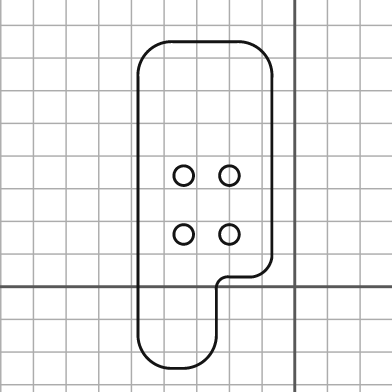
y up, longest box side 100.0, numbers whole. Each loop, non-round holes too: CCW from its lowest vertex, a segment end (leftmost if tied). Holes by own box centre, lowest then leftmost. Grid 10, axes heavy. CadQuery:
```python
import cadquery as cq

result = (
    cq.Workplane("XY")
    .moveTo(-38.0, -25.0)
    .lineTo(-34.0, -25.0)
    .threePointArc((-27.0, -22.0), (-24.0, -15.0))
    .lineTo(-24.0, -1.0)
    .threePointArc((-23.0, 2.0), (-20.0, 3.0))
    .lineTo(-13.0, 3.0)
    .threePointArc((-9.0, 5.0), (-7.0, 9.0))
    .lineTo(-7.0, 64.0)
    .threePointArc((-10.0, 72.0), (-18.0, 75.0))
    .lineTo(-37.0, 75.0)
    .threePointArc((-45.0, 72.0), (-48.0, 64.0))
    .lineTo(-48.0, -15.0)
    .threePointArc((-45.0, -22.0), (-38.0, -25.0))
    .close()
    .moveTo(-34.0, 16.0)
    .circle(3.0)
    .moveTo(-20.0, 16.0)
    .circle(3.0)
    .moveTo(-34.0, 34.0)
    .circle(3.0)
    .moveTo(-20.0, 34.0)
    .circle(3.0)
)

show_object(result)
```